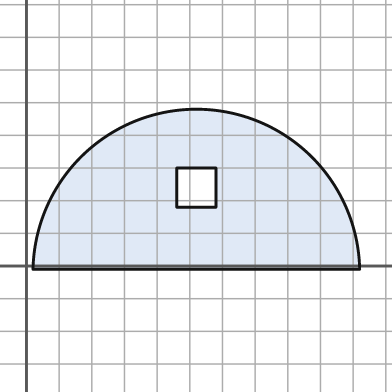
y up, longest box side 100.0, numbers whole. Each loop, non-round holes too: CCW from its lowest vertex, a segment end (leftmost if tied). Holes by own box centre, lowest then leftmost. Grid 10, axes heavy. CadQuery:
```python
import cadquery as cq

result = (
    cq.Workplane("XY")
    .moveTo(2.0, -1.0)
    .lineTo(102.0, -1.0)
    .threePointArc((52.0, 48.0), (2.0, -1.0))
    .close()
    .moveTo(46.0, 18.0)
    .lineTo(58.0, 18.0)
    .lineTo(58.0, 30.0)
    .lineTo(46.0, 30.0)
    .close()
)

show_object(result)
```